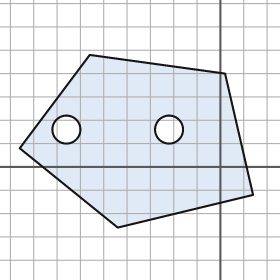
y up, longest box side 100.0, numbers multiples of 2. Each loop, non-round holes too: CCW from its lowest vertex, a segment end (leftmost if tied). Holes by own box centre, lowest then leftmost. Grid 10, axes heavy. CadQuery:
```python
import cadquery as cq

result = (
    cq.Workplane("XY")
    .moveTo(-44.0, -26.0)
    .lineTo(14.0, -12.0)
    .lineTo(2.0, 40.0)
    .lineTo(-56.0, 48.0)
    .lineTo(-86.0, 8.0)
    .close()
    .moveTo(-66.0, 16.0)
    .circle(6.0)
    .moveTo(-22.0, 16.0)
    .circle(6.0)
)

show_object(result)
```